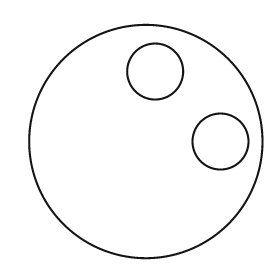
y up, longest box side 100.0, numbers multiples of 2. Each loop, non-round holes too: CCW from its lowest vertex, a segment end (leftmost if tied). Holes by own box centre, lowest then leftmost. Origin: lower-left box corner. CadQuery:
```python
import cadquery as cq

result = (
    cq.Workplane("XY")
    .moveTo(50.0, 50.0)
    .circle(50.0)
    .moveTo(82.0, 50.0)
    .circle(12.0)
    .moveTo(54.0, 80.0)
    .circle(12.0)
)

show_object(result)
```